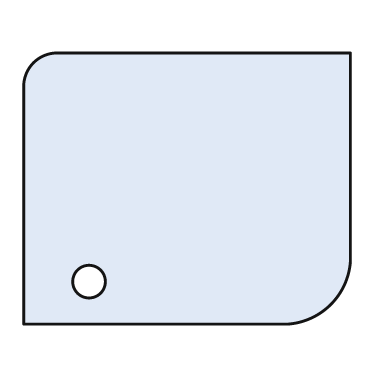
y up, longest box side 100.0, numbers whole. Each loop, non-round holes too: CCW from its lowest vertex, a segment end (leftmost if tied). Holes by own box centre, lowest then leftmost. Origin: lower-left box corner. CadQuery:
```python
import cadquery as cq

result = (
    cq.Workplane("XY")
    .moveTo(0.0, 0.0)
    .lineTo(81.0, 0.0)
    .threePointArc((94.0, 6.0), (100.0, 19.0))
    .lineTo(100.0, 83.0)
    .lineTo(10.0, 83.0)
    .threePointArc((3.0, 80.0), (0.0, 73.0))
    .close()
    .moveTo(20.0, 13.0)
    .circle(5.0)
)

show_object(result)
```